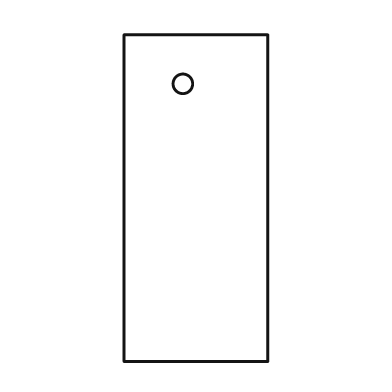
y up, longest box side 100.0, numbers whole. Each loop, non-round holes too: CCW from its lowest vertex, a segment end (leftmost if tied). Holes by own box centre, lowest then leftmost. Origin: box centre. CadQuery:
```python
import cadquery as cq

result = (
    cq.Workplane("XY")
    .moveTo(-22.0, -50.0)
    .lineTo(22.0, -50.0)
    .lineTo(22.0, 50.0)
    .lineTo(-22.0, 50.0)
    .close()
    .moveTo(-4.0, 35.0)
    .circle(3.0)
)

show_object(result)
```